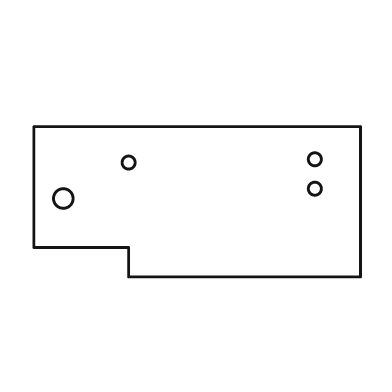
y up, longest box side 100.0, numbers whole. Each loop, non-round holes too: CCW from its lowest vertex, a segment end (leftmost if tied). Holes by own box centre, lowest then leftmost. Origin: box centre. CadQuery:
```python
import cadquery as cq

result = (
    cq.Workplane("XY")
    .moveTo(-21.0, -23.0)
    .lineTo(50.0, -23.0)
    .lineTo(50.0, 23.0)
    .lineTo(-50.0, 23.0)
    .lineTo(-50.0, -14.0)
    .lineTo(-21.0, -14.0)
    .close()
    .moveTo(-41.0, 1.0)
    .circle(3.0)
    .moveTo(36.0, 4.0)
    .circle(2.0)
    .moveTo(-21.0, 12.0)
    .circle(2.0)
    .moveTo(36.0, 13.0)
    .circle(2.0)
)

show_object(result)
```